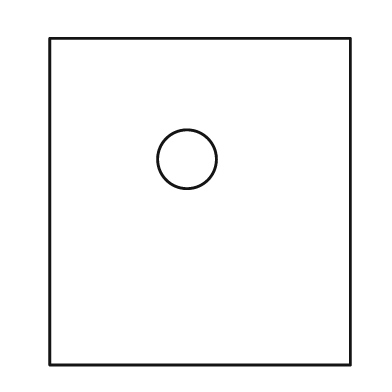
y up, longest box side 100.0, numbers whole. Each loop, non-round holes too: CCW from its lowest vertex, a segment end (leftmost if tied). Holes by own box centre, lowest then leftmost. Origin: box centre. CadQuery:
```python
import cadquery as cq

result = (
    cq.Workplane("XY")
    .moveTo(-46.0, -50.0)
    .lineTo(46.0, -50.0)
    .lineTo(46.0, 50.0)
    .lineTo(-46.0, 50.0)
    .close()
    .moveTo(-4.0, 13.0)
    .circle(9.0)
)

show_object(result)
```